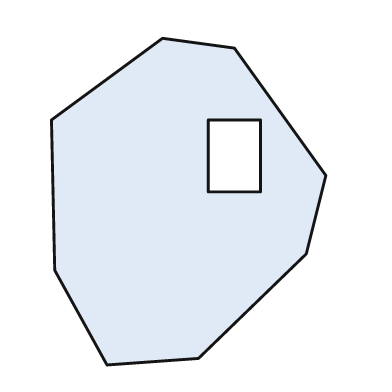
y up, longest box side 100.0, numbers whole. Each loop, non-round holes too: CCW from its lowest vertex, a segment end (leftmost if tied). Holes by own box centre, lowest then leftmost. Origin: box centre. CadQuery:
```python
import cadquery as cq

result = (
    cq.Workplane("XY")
    .moveTo(-25.0, -50.0)
    .lineTo(3.0, -48.0)
    .lineTo(36.0, -16.0)
    .lineTo(42.0, 8.0)
    .lineTo(14.0, 47.0)
    .lineTo(-8.0, 50.0)
    .lineTo(-42.0, 25.0)
    .lineTo(-41.0, -21.0)
    .close()
    .moveTo(6.0, 3.0)
    .lineTo(22.0, 3.0)
    .lineTo(22.0, 25.0)
    .lineTo(6.0, 25.0)
    .close()
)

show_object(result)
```